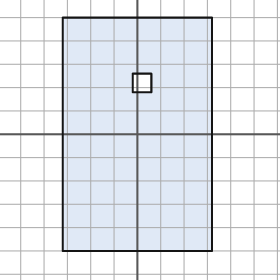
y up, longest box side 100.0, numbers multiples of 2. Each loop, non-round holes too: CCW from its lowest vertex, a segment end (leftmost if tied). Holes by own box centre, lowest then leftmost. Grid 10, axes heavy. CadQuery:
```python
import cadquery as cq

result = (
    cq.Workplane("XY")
    .moveTo(-32.0, -50.0)
    .lineTo(32.0, -50.0)
    .lineTo(32.0, 50.0)
    .lineTo(-32.0, 50.0)
    .close()
    .moveTo(-2.0, 18.0)
    .lineTo(6.0, 18.0)
    .lineTo(6.0, 26.0)
    .lineTo(-2.0, 26.0)
    .close()
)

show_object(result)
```